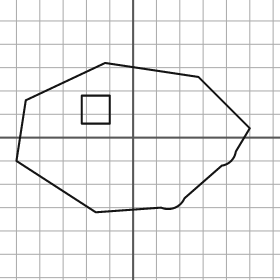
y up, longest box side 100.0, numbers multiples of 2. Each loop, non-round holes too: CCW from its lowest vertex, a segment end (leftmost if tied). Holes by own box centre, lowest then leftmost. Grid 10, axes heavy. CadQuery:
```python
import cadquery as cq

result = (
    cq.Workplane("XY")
    .moveTo(-16.0, -32.0)
    .lineTo(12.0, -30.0)
    .threePointArc((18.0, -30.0), (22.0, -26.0))
    .lineTo(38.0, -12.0)
    .threePointArc((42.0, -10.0), (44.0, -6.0))
    .lineTo(50.0, 4.0)
    .lineTo(28.0, 26.0)
    .lineTo(-12.0, 32.0)
    .lineTo(-46.0, 16.0)
    .lineTo(-50.0, -10.0)
    .close()
    .moveTo(-22.0, 6.0)
    .lineTo(-10.0, 6.0)
    .lineTo(-10.0, 18.0)
    .lineTo(-22.0, 18.0)
    .close()
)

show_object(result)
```